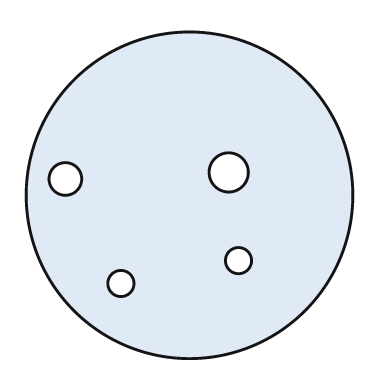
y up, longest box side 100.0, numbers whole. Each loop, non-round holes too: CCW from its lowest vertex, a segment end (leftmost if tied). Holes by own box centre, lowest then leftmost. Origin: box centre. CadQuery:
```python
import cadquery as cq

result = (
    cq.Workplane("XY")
    .moveTo(0.0, 0.0)
    .circle(50.0)
    .moveTo(-21.0, -27.0)
    .circle(4.0)
    .moveTo(15.0, -20.0)
    .circle(4.0)
    .moveTo(-38.0, 5.0)
    .circle(5.0)
    .moveTo(12.0, 7.0)
    .circle(6.0)
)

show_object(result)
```